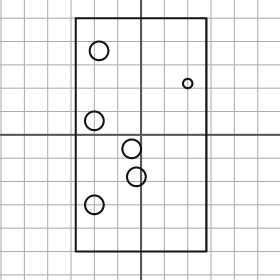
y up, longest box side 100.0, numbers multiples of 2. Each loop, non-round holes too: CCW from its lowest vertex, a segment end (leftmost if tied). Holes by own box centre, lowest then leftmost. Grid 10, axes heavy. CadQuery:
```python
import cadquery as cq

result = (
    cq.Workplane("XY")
    .moveTo(-28.0, -50.0)
    .lineTo(28.0, -50.0)
    .lineTo(28.0, 50.0)
    .lineTo(-28.0, 50.0)
    .close()
    .moveTo(-20.0, -30.0)
    .circle(4.0)
    .moveTo(-2.0, -18.0)
    .circle(4.0)
    .moveTo(-4.0, -6.0)
    .circle(4.0)
    .moveTo(-20.0, 6.0)
    .circle(4.0)
    .moveTo(20.0, 22.0)
    .circle(2.0)
    .moveTo(-18.0, 36.0)
    .circle(4.0)
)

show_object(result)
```